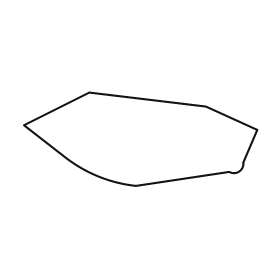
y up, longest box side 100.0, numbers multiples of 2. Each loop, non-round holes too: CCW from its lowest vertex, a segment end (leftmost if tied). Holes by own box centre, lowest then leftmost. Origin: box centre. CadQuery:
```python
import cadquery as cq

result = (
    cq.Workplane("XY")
    .moveTo(-2.0, -20.0)
    .lineTo(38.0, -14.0)
    .threePointArc((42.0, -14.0), (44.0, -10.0))
    .lineTo(50.0, 4.0)
    .lineTo(28.0, 14.0)
    .lineTo(-22.0, 20.0)
    .lineTo(-50.0, 6.0)
    .lineTo(-32.0, -8.0)
    .threePointArc((-18.0, -16.0), (-2.0, -20.0))
    .close()
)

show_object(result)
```